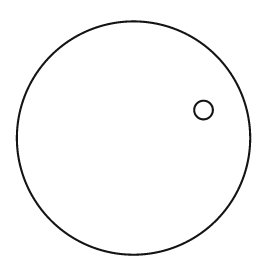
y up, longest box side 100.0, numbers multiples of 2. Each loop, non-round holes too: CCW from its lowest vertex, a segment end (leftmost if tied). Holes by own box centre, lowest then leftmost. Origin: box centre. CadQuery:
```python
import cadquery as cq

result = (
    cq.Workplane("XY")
    .moveTo(0.0, 0.0)
    .circle(50.0)
    .moveTo(30.0, 12.0)
    .circle(4.0)
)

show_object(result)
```